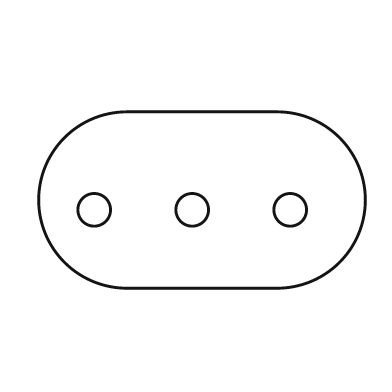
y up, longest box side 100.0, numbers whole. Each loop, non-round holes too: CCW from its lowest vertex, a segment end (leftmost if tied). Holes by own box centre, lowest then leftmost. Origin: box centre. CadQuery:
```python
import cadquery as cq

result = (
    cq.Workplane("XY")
    .moveTo(-23.0, -27.0)
    .lineTo(23.0, -27.0)
    .threePointArc((50.0, 0.0), (23.0, 27.0))
    .lineTo(-23.0, 27.0)
    .threePointArc((-50.0, 0.0), (-23.0, -27.0))
    .close()
    .moveTo(-33.0, -3.0)
    .circle(5.0)
    .moveTo(-3.0, -3.0)
    .circle(5.0)
    .moveTo(27.0, -3.0)
    .circle(5.0)
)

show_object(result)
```